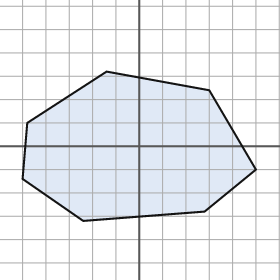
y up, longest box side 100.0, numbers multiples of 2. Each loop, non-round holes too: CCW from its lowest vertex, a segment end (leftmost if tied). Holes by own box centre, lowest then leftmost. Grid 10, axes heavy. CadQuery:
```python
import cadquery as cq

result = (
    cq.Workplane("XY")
    .moveTo(-24.0, -32.0)
    .lineTo(28.0, -28.0)
    .lineTo(50.0, -10.0)
    .lineTo(30.0, 24.0)
    .lineTo(-14.0, 32.0)
    .lineTo(-48.0, 10.0)
    .lineTo(-50.0, -14.0)
    .close()
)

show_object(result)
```